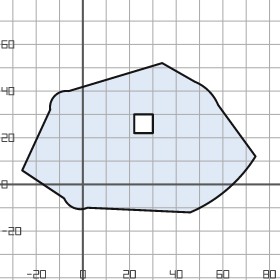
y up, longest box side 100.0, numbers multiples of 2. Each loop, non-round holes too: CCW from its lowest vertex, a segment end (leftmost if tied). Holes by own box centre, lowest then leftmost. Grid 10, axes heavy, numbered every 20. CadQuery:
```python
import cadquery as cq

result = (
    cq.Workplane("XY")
    .moveTo(46.0, -12.0)
    .threePointArc((62.0, -2.0), (74.0, 12.0))
    .lineTo(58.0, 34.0)
    .threePointArc((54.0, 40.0), (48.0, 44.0))
    .lineTo(34.0, 52.0)
    .lineTo(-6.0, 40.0)
    .threePointArc((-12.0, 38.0), (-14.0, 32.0))
    .lineTo(-26.0, 6.0)
    .lineTo(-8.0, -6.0)
    .threePointArc((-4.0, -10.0), (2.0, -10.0))
    .close()
    .moveTo(22.0, 22.0)
    .lineTo(30.0, 22.0)
    .lineTo(30.0, 30.0)
    .lineTo(22.0, 30.0)
    .close()
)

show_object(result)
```